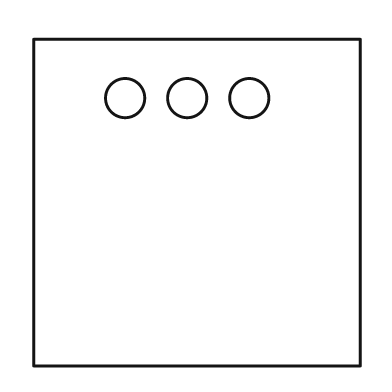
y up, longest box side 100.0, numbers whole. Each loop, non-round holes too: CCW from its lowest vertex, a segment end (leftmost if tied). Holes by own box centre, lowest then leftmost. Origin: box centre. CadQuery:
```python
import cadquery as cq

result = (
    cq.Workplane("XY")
    .moveTo(-50.0, -50.0)
    .lineTo(50.0, -50.0)
    .lineTo(50.0, 50.0)
    .lineTo(-50.0, 50.0)
    .close()
    .moveTo(-22.0, 32.0)
    .circle(6.0)
    .moveTo(-3.0, 32.0)
    .circle(6.0)
    .moveTo(16.0, 32.0)
    .circle(6.0)
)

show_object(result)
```